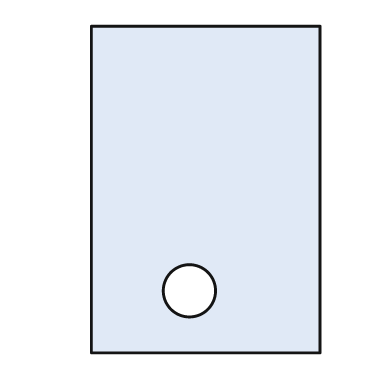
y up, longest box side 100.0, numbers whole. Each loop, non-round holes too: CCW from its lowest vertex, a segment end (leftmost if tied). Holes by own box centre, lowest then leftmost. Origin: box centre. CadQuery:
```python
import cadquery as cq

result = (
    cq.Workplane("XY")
    .moveTo(-35.0, -50.0)
    .lineTo(35.0, -50.0)
    .lineTo(35.0, 50.0)
    .lineTo(-35.0, 50.0)
    .close()
    .moveTo(-5.0, -31.0)
    .circle(8.0)
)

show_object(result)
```